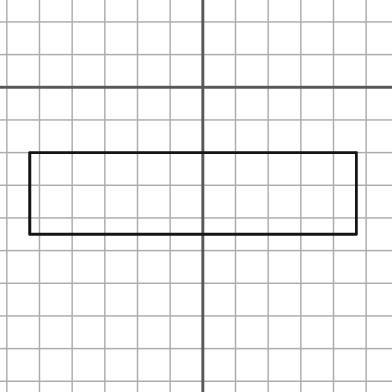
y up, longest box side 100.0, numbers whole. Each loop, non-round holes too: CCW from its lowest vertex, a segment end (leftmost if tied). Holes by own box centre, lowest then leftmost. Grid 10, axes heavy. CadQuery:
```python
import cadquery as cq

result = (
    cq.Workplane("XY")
    .moveTo(-53.0, -45.0)
    .lineTo(47.0, -45.0)
    .lineTo(47.0, -20.0)
    .lineTo(-53.0, -20.0)
    .close()
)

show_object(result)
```